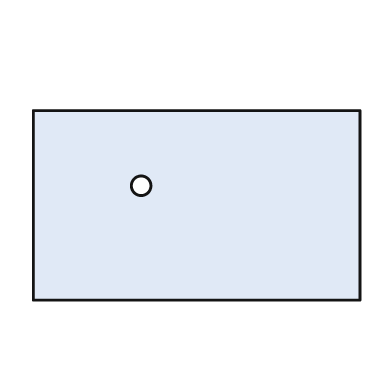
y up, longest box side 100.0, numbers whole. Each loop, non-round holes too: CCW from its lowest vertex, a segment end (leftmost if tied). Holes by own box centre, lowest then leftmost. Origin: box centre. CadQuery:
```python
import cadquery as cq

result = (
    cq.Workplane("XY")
    .moveTo(-50.0, -29.0)
    .lineTo(50.0, -29.0)
    .lineTo(50.0, 29.0)
    .lineTo(-50.0, 29.0)
    .close()
    .moveTo(-17.0, 6.0)
    .circle(3.0)
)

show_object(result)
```